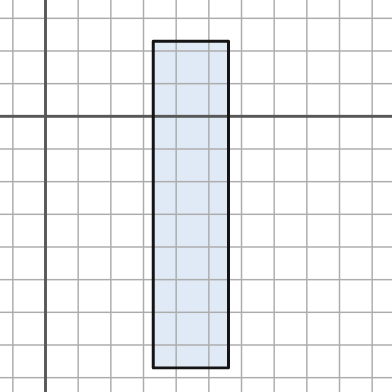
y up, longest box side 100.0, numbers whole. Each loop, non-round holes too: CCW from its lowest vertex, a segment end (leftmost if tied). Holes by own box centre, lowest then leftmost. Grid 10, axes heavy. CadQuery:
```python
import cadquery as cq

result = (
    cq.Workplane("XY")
    .moveTo(33.0, -77.0)
    .lineTo(56.0, -77.0)
    .lineTo(56.0, 23.0)
    .lineTo(33.0, 23.0)
    .close()
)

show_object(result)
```